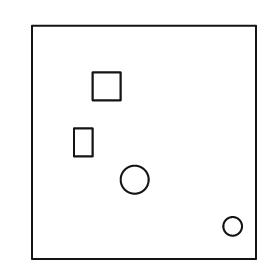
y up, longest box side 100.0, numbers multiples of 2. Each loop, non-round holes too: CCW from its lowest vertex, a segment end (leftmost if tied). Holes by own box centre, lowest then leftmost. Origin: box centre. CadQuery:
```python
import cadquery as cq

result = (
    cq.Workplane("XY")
    .moveTo(-48.0, -50.0)
    .lineTo(48.0, -50.0)
    .lineTo(48.0, 50.0)
    .lineTo(-48.0, 50.0)
    .close()
    .moveTo(38.0, -36.0)
    .circle(4.0)
    .moveTo(-4.0, -16.0)
    .circle(6.0)
    .moveTo(-30.0, -6.0)
    .lineTo(-22.0, -6.0)
    .lineTo(-22.0, 6.0)
    .lineTo(-30.0, 6.0)
    .close()
    .moveTo(-22.0, 18.0)
    .lineTo(-10.0, 18.0)
    .lineTo(-10.0, 30.0)
    .lineTo(-22.0, 30.0)
    .close()
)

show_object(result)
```